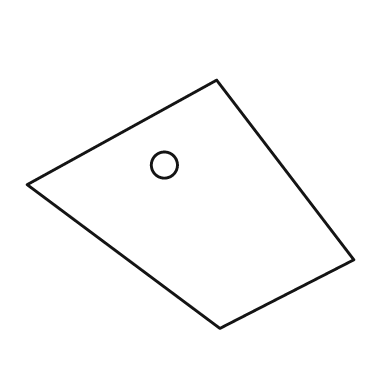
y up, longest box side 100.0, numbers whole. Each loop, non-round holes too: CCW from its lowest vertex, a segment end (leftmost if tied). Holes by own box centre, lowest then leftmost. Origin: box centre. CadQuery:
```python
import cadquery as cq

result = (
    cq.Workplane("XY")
    .moveTo(9.0, -38.0)
    .lineTo(50.0, -17.0)
    .lineTo(8.0, 38.0)
    .lineTo(-50.0, 6.0)
    .close()
    .moveTo(-8.0, 12.0)
    .circle(4.0)
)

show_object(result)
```